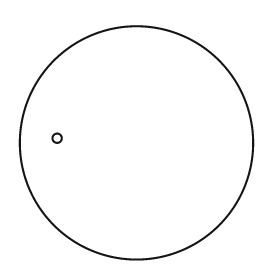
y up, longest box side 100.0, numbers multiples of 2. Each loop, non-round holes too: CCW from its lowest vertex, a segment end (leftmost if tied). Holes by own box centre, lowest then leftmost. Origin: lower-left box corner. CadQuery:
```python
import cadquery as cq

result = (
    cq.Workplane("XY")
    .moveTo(50.0, 50.0)
    .circle(50.0)
    .moveTo(16.0, 52.0)
    .circle(2.0)
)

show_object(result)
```